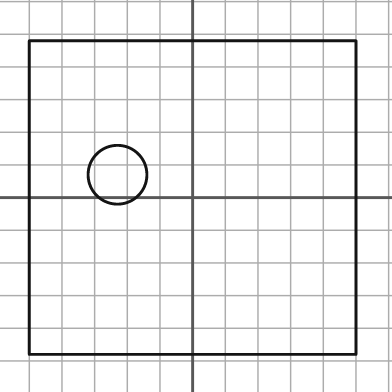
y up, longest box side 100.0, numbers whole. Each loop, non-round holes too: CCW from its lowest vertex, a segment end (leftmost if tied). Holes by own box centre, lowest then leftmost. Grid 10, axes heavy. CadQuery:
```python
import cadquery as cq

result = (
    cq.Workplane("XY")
    .moveTo(-50.0, -48.0)
    .lineTo(50.0, -48.0)
    .lineTo(50.0, 48.0)
    .lineTo(-50.0, 48.0)
    .close()
    .moveTo(-23.0, 7.0)
    .circle(9.0)
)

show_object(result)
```